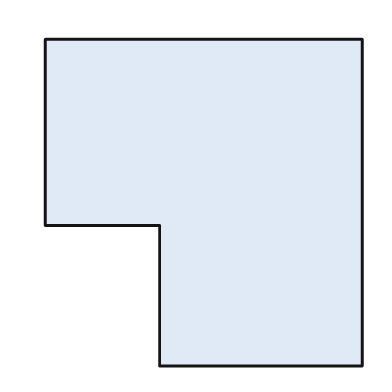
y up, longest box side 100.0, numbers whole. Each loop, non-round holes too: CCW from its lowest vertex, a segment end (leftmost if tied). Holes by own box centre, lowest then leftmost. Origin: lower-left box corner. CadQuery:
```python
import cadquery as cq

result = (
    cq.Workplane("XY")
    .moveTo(35.0, 0.0)
    .lineTo(97.0, 0.0)
    .lineTo(97.0, 100.0)
    .lineTo(0.0, 100.0)
    .lineTo(0.0, 43.0)
    .lineTo(35.0, 43.0)
    .close()
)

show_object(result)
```